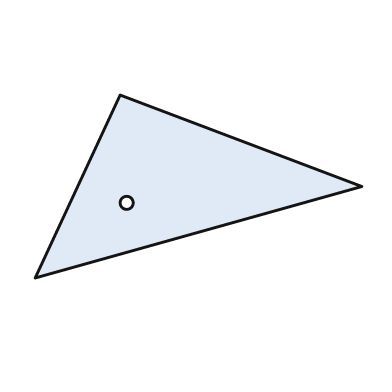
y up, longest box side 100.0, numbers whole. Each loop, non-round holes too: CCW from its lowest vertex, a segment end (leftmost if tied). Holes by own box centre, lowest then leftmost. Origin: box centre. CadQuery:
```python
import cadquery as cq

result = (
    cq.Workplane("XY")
    .moveTo(-50.0, -28.0)
    .lineTo(50.0, 0.0)
    .lineTo(-24.0, 28.0)
    .close()
    .moveTo(-22.0, -5.0)
    .circle(2.0)
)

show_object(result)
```